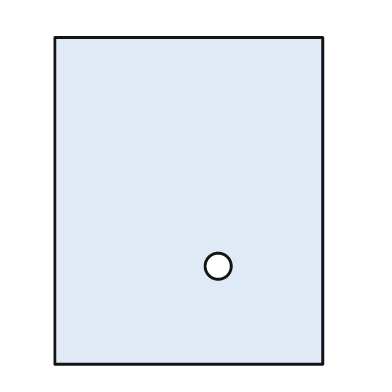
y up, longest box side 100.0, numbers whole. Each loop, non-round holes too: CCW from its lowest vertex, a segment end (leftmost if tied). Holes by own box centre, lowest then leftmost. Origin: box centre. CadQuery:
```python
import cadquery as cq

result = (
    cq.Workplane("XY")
    .moveTo(-41.0, -50.0)
    .lineTo(41.0, -50.0)
    .lineTo(41.0, 50.0)
    .lineTo(-41.0, 50.0)
    .close()
    .moveTo(9.0, -20.0)
    .circle(4.0)
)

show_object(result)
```